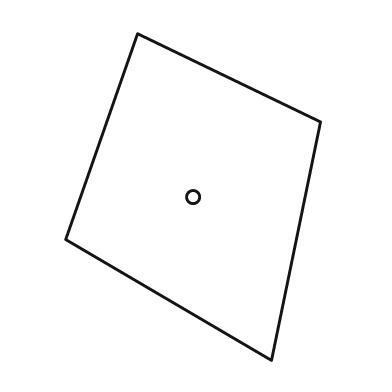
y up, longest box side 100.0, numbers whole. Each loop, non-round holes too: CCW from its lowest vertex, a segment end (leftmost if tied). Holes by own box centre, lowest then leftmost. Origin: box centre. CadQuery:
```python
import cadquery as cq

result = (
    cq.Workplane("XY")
    .moveTo(24.0, -50.0)
    .lineTo(39.0, 23.0)
    .lineTo(-17.0, 50.0)
    .lineTo(-39.0, -13.0)
    .close()
    .moveTo(0.0, 0.0)
    .circle(2.0)
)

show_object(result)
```